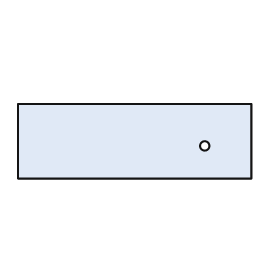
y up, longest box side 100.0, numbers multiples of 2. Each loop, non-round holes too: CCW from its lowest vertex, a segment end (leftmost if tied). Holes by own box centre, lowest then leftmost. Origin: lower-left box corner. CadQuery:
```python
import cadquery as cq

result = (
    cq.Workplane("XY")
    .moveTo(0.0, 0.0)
    .lineTo(100.0, 0.0)
    .lineTo(100.0, 32.0)
    .lineTo(0.0, 32.0)
    .close()
    .moveTo(80.0, 14.0)
    .circle(2.0)
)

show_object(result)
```